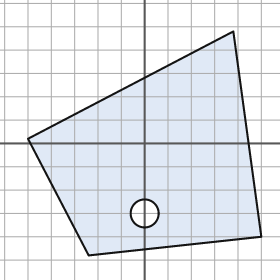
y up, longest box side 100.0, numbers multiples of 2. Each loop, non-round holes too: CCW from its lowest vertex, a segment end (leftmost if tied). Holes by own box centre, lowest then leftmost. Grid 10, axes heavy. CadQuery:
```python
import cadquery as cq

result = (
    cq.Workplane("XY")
    .moveTo(-24.0, -48.0)
    .lineTo(50.0, -40.0)
    .lineTo(38.0, 48.0)
    .lineTo(-50.0, 2.0)
    .close()
    .moveTo(0.0, -30.0)
    .circle(6.0)
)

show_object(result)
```